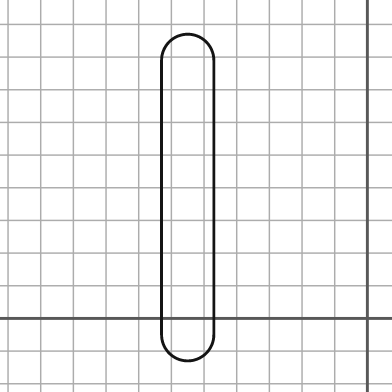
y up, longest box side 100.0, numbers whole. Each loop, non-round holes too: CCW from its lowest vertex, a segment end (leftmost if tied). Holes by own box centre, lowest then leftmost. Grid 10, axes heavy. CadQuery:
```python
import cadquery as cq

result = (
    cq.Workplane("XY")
    .moveTo(-63.0, -5.0)
    .threePointArc((-55.0, -13.0), (-47.0, -5.0))
    .lineTo(-47.0, 79.0)
    .threePointArc((-55.0, 87.0), (-63.0, 79.0))
    .close()
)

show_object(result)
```